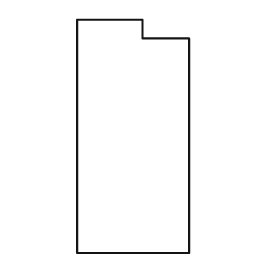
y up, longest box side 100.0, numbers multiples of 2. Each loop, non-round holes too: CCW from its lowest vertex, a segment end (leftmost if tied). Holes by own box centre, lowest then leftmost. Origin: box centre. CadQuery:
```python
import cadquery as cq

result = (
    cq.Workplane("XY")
    .moveTo(-24.0, -50.0)
    .lineTo(24.0, -50.0)
    .lineTo(24.0, 42.0)
    .lineTo(4.0, 42.0)
    .lineTo(4.0, 50.0)
    .lineTo(-24.0, 50.0)
    .close()
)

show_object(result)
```